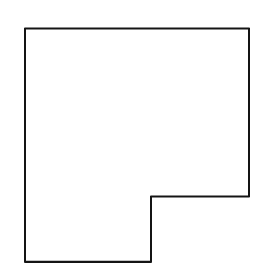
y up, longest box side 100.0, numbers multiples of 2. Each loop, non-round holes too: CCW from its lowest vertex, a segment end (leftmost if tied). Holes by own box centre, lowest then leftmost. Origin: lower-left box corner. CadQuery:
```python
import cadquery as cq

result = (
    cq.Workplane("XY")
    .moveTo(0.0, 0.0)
    .lineTo(54.0, 0.0)
    .lineTo(54.0, 28.0)
    .lineTo(96.0, 28.0)
    .lineTo(96.0, 100.0)
    .lineTo(0.0, 100.0)
    .close()
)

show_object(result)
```